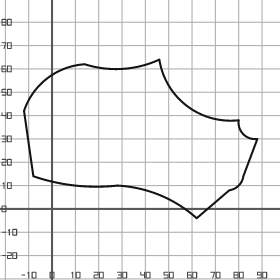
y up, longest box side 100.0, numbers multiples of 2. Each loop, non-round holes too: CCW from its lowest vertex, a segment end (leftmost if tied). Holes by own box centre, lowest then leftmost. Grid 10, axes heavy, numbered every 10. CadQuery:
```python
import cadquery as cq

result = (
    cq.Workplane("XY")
    .moveTo(62.0, -4.0)
    .lineTo(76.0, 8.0)
    .threePointArc((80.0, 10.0), (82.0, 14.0))
    .lineTo(88.0, 30.0)
    .threePointArc((82.0, 32.0), (80.0, 38.0))
    .threePointArc((58.0, 44.0), (46.0, 64.0))
    .threePointArc((30.0, 60.0), (14.0, 62.0))
    .threePointArc((-2.0, 56.0), (-12.0, 42.0))
    .lineTo(-8.0, 14.0)
    .threePointArc((10.0, 10.0), (28.0, 10.0))
    .threePointArc((46.0, 6.0), (62.0, -4.0))
    .close()
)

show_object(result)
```